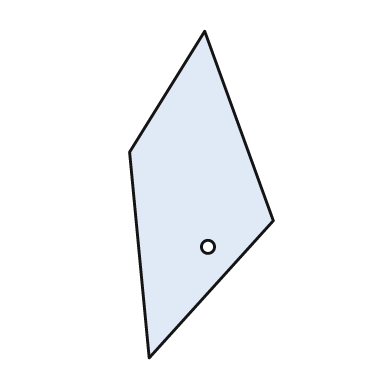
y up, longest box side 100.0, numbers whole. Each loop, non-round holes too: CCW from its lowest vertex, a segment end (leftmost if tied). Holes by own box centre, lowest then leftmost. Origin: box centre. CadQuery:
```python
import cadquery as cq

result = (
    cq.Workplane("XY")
    .moveTo(-16.0, -50.0)
    .lineTo(22.0, -8.0)
    .lineTo(1.0, 50.0)
    .lineTo(-22.0, 13.0)
    .close()
    .moveTo(2.0, -16.0)
    .circle(2.0)
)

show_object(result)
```